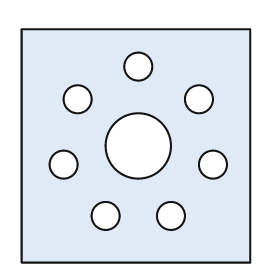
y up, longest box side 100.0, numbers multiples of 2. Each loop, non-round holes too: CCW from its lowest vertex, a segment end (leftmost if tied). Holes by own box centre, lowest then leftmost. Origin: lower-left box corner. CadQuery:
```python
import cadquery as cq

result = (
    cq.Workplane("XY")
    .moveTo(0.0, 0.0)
    .lineTo(98.0, 0.0)
    .lineTo(98.0, 100.0)
    .lineTo(0.0, 100.0)
    .close()
    .moveTo(36.0, 20.0)
    .circle(6.0)
    .moveTo(64.0, 20.0)
    .circle(6.0)
    .moveTo(18.0, 42.0)
    .circle(6.0)
    .moveTo(82.0, 42.0)
    .circle(6.0)
    .moveTo(50.0, 50.0)
    .circle(14.0)
    .moveTo(24.0, 70.0)
    .circle(6.0)
    .moveTo(76.0, 70.0)
    .circle(6.0)
    .moveTo(50.0, 84.0)
    .circle(6.0)
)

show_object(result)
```